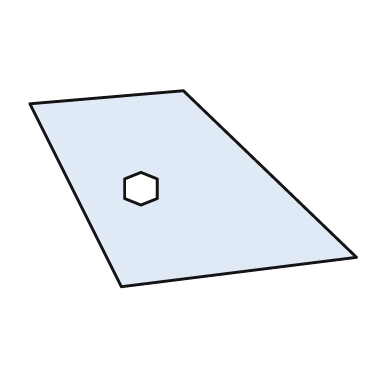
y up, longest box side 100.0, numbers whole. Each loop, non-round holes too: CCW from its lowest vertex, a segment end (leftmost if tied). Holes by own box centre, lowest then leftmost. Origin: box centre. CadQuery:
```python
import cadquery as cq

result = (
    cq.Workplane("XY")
    .moveTo(-22.0, -30.0)
    .lineTo(50.0, -21.0)
    .lineTo(-3.0, 30.0)
    .lineTo(-50.0, 26.0)
    .close()
    .moveTo(-16.0, -5.0)
    .lineTo(-11.0, -3.0)
    .lineTo(-11.0, 3.0)
    .lineTo(-16.0, 5.0)
    .lineTo(-21.0, 3.0)
    .lineTo(-21.0, -3.0)
    .close()
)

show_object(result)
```